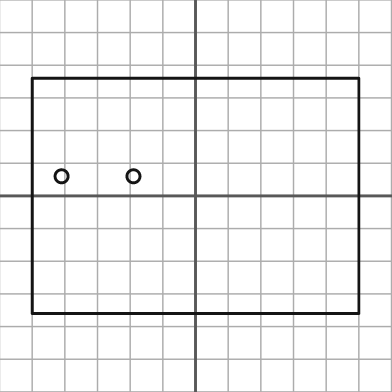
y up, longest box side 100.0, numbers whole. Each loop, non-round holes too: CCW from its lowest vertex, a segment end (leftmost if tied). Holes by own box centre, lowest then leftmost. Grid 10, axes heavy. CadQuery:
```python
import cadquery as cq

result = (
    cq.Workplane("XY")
    .moveTo(-50.0, -36.0)
    .lineTo(50.0, -36.0)
    .lineTo(50.0, 36.0)
    .lineTo(-50.0, 36.0)
    .close()
    .moveTo(-41.0, 6.0)
    .circle(2.0)
    .moveTo(-19.0, 6.0)
    .circle(2.0)
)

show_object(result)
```